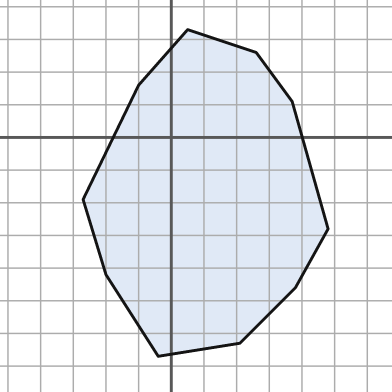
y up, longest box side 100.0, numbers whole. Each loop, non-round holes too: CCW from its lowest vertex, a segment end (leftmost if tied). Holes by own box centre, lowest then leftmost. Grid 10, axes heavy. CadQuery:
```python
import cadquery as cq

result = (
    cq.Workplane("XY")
    .moveTo(-4.0, -67.0)
    .lineTo(21.0, -63.0)
    .lineTo(38.0, -46.0)
    .lineTo(48.0, -28.0)
    .lineTo(37.0, 11.0)
    .lineTo(26.0, 26.0)
    .lineTo(5.0, 33.0)
    .lineTo(-10.0, 16.0)
    .lineTo(-27.0, -19.0)
    .lineTo(-20.0, -42.0)
    .close()
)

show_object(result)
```